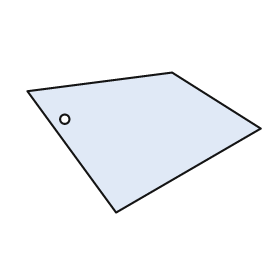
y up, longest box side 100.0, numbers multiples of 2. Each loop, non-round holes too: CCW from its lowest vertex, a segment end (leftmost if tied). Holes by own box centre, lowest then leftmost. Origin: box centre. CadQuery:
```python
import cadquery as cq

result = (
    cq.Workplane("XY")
    .moveTo(-12.0, -30.0)
    .lineTo(50.0, 6.0)
    .lineTo(12.0, 30.0)
    .lineTo(-50.0, 22.0)
    .close()
    .moveTo(-34.0, 10.0)
    .circle(2.0)
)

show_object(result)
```